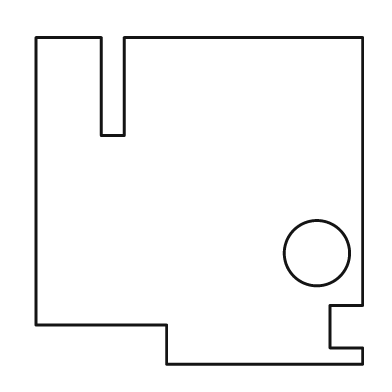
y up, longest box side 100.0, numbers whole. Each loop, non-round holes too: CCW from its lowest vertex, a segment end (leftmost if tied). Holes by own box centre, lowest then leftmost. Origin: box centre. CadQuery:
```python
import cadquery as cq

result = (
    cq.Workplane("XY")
    .moveTo(-10.0, -50.0)
    .lineTo(50.0, -50.0)
    .lineTo(50.0, -45.0)
    .lineTo(40.0, -45.0)
    .lineTo(40.0, -32.0)
    .lineTo(50.0, -32.0)
    .lineTo(50.0, 50.0)
    .lineTo(-23.0, 50.0)
    .lineTo(-23.0, 20.0)
    .lineTo(-30.0, 20.0)
    .lineTo(-30.0, 50.0)
    .lineTo(-50.0, 50.0)
    .lineTo(-50.0, -38.0)
    .lineTo(-10.0, -38.0)
    .close()
    .moveTo(36.0, -16.0)
    .circle(10.0)
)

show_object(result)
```